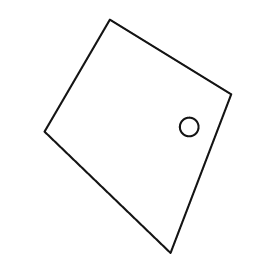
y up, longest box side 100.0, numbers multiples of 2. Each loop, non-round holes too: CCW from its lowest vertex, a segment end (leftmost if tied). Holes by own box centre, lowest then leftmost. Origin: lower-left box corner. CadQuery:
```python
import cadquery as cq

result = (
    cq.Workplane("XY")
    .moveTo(54.0, 0.0)
    .lineTo(80.0, 68.0)
    .lineTo(28.0, 100.0)
    .lineTo(0.0, 52.0)
    .close()
    .moveTo(62.0, 54.0)
    .circle(4.0)
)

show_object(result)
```